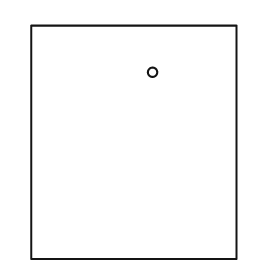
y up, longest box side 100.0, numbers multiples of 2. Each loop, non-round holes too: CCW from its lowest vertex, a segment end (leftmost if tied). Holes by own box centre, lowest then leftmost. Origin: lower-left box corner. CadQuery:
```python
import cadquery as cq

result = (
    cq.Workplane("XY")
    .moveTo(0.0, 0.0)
    .lineTo(88.0, 0.0)
    .lineTo(88.0, 100.0)
    .lineTo(0.0, 100.0)
    .close()
    .moveTo(52.0, 80.0)
    .circle(2.0)
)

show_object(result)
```